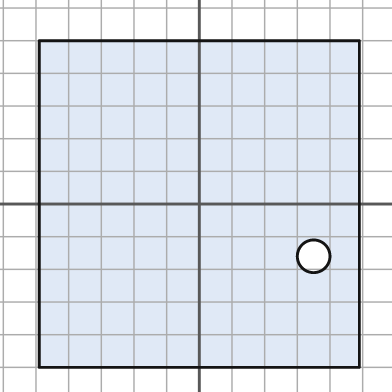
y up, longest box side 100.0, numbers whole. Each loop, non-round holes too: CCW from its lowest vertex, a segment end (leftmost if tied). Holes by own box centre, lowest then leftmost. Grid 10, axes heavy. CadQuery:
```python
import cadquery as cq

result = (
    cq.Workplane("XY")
    .moveTo(-49.0, -50.0)
    .lineTo(49.0, -50.0)
    .lineTo(49.0, 50.0)
    .lineTo(-49.0, 50.0)
    .close()
    .moveTo(35.0, -16.0)
    .circle(5.0)
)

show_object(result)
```